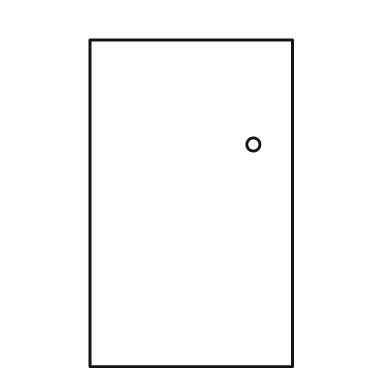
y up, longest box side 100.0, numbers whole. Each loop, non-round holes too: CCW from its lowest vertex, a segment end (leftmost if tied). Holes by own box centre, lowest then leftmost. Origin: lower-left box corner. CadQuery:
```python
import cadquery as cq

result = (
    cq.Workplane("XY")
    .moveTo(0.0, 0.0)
    .lineTo(62.0, 0.0)
    .lineTo(62.0, 100.0)
    .lineTo(0.0, 100.0)
    .close()
    .moveTo(50.0, 68.0)
    .circle(2.0)
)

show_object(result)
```